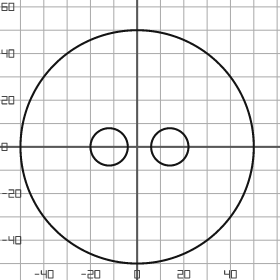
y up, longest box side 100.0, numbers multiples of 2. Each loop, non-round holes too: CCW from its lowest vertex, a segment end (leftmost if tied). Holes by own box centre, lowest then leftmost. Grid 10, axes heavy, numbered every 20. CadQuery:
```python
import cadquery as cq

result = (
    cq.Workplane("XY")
    .moveTo(0.0, 0.0)
    .circle(50.0)
    .moveTo(-12.0, 0.0)
    .circle(8.0)
    .moveTo(14.0, 0.0)
    .circle(8.0)
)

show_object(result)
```